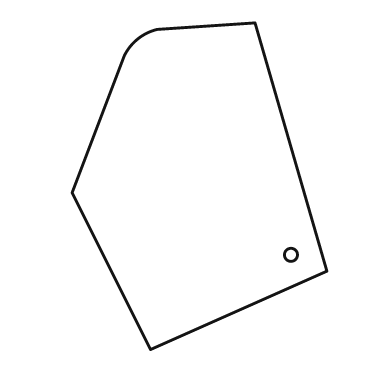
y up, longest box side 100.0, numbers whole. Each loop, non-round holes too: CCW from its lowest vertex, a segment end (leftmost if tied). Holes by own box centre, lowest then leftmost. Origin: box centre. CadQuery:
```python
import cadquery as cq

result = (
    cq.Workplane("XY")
    .moveTo(-15.0, -50.0)
    .lineTo(39.0, -26.0)
    .lineTo(17.0, 50.0)
    .lineTo(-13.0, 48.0)
    .threePointArc((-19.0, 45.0), (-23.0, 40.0))
    .lineTo(-39.0, -2.0)
    .close()
    .moveTo(28.0, -21.0)
    .circle(2.0)
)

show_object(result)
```